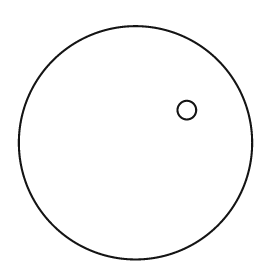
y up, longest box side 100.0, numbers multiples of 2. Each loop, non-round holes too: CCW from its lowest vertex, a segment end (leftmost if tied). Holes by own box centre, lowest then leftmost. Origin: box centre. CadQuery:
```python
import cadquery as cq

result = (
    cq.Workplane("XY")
    .moveTo(0.0, 0.0)
    .circle(50.0)
    .moveTo(22.0, 14.0)
    .circle(4.0)
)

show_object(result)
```